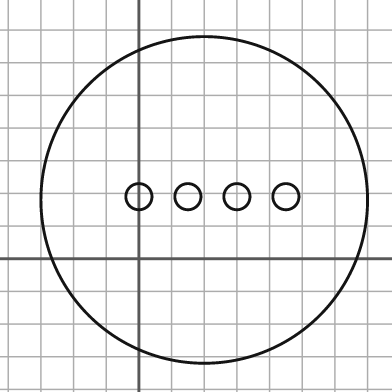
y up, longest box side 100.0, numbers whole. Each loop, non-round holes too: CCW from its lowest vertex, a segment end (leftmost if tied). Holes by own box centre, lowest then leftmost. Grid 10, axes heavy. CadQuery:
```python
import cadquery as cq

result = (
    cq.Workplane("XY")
    .moveTo(20.0, 18.0)
    .circle(50.0)
    .moveTo(0.0, 19.0)
    .circle(4.0)
    .moveTo(15.0, 19.0)
    .circle(4.0)
    .moveTo(30.0, 19.0)
    .circle(4.0)
    .moveTo(45.0, 19.0)
    .circle(4.0)
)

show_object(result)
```